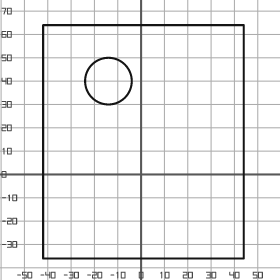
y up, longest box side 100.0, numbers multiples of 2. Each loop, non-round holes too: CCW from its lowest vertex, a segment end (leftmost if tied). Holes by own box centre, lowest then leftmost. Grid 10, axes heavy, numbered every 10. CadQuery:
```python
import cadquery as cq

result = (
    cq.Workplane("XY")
    .moveTo(-42.0, -36.0)
    .lineTo(44.0, -36.0)
    .lineTo(44.0, 64.0)
    .lineTo(-42.0, 64.0)
    .close()
    .moveTo(-14.0, 40.0)
    .circle(10.0)
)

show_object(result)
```